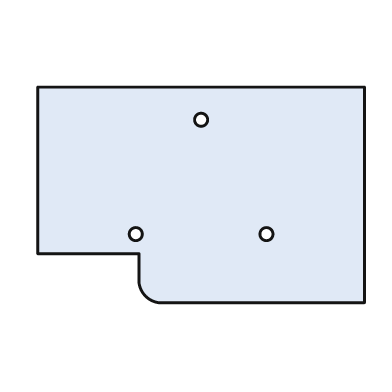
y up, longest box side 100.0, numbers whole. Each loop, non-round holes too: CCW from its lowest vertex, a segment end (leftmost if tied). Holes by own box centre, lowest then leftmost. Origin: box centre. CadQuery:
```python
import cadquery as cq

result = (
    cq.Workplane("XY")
    .moveTo(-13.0, -33.0)
    .lineTo(50.0, -33.0)
    .lineTo(50.0, 33.0)
    .lineTo(-50.0, 33.0)
    .lineTo(-50.0, -18.0)
    .lineTo(-19.0, -18.0)
    .lineTo(-19.0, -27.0)
    .threePointArc((-17.0, -31.0), (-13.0, -33.0))
    .close()
    .moveTo(-20.0, -12.0)
    .circle(2.0)
    .moveTo(20.0, -12.0)
    .circle(2.0)
    .moveTo(0.0, 23.0)
    .circle(2.0)
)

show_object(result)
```